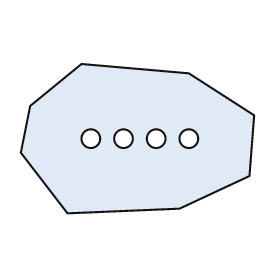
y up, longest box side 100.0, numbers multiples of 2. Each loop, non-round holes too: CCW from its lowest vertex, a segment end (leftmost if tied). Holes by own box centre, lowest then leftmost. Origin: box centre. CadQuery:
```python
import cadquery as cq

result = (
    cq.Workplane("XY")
    .moveTo(-30.0, -32.0)
    .lineTo(18.0, -30.0)
    .lineTo(48.0, -16.0)
    .lineTo(50.0, 10.0)
    .lineTo(22.0, 28.0)
    .lineTo(-24.0, 32.0)
    .lineTo(-46.0, 14.0)
    .lineTo(-50.0, -6.0)
    .close()
    .moveTo(-20.0, 0.0)
    .circle(4.0)
    .moveTo(-6.0, 0.0)
    .circle(4.0)
    .moveTo(8.0, 0.0)
    .circle(4.0)
    .moveTo(22.0, 0.0)
    .circle(4.0)
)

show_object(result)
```